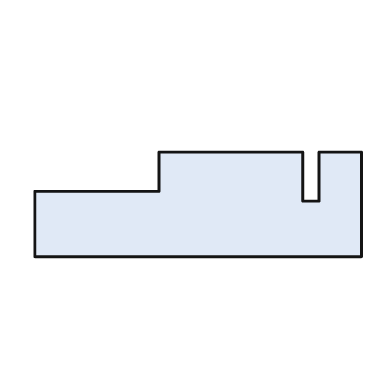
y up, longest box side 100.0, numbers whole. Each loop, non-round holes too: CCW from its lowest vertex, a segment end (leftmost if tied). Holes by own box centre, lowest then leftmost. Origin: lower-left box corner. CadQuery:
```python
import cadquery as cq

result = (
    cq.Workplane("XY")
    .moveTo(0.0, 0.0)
    .lineTo(100.0, 0.0)
    .lineTo(100.0, 32.0)
    .lineTo(87.0, 32.0)
    .lineTo(87.0, 17.0)
    .lineTo(82.0, 17.0)
    .lineTo(82.0, 32.0)
    .lineTo(38.0, 32.0)
    .lineTo(38.0, 20.0)
    .lineTo(0.0, 20.0)
    .close()
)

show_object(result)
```